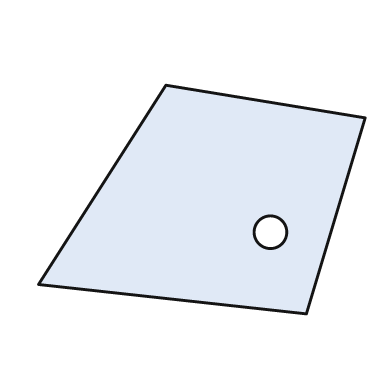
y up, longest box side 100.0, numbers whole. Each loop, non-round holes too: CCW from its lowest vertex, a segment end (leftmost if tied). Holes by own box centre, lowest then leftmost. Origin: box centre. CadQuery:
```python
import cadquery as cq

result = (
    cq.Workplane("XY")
    .moveTo(32.0, -35.0)
    .lineTo(50.0, 25.0)
    .lineTo(-11.0, 35.0)
    .lineTo(-50.0, -26.0)
    .close()
    .moveTo(21.0, -10.0)
    .circle(5.0)
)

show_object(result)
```